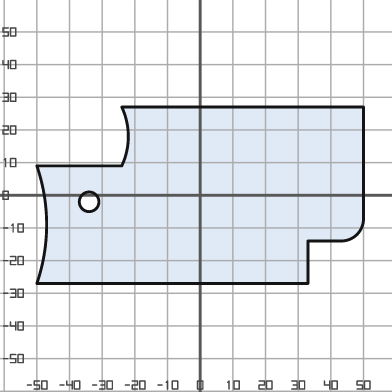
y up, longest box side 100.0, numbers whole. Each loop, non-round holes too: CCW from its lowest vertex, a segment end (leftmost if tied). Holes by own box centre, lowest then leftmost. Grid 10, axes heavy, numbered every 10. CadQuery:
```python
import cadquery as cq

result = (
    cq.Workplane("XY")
    .moveTo(-50.0, -27.0)
    .lineTo(33.0, -27.0)
    .lineTo(33.0, -14.0)
    .lineTo(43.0, -14.0)
    .threePointArc((48.0, -12.0), (50.0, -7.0))
    .lineTo(50.0, 27.0)
    .lineTo(-24.0, 27.0)
    .threePointArc((-22.0, 18.0), (-24.0, 9.0))
    .lineTo(-50.0, 9.0)
    .threePointArc((-47.0, -9.0), (-50.0, -27.0))
    .close()
    .moveTo(-34.0, -2.0)
    .circle(3.0)
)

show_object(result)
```